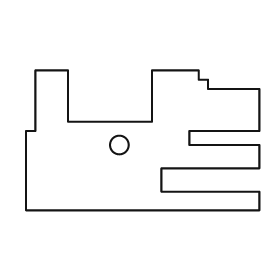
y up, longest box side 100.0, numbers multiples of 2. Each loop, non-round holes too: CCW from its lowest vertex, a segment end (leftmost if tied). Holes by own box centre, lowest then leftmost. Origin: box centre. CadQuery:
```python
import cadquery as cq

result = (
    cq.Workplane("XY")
    .moveTo(-50.0, -30.0)
    .lineTo(50.0, -30.0)
    .lineTo(50.0, -22.0)
    .lineTo(8.0, -22.0)
    .lineTo(8.0, -12.0)
    .lineTo(50.0, -12.0)
    .lineTo(50.0, -2.0)
    .lineTo(20.0, -2.0)
    .lineTo(20.0, 4.0)
    .lineTo(50.0, 4.0)
    .lineTo(50.0, 22.0)
    .lineTo(28.0, 22.0)
    .lineTo(28.0, 26.0)
    .lineTo(24.0, 26.0)
    .lineTo(24.0, 30.0)
    .lineTo(4.0, 30.0)
    .lineTo(4.0, 8.0)
    .lineTo(-32.0, 8.0)
    .lineTo(-32.0, 30.0)
    .lineTo(-46.0, 30.0)
    .lineTo(-46.0, 4.0)
    .lineTo(-50.0, 4.0)
    .close()
    .moveTo(-10.0, -2.0)
    .circle(4.0)
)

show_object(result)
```